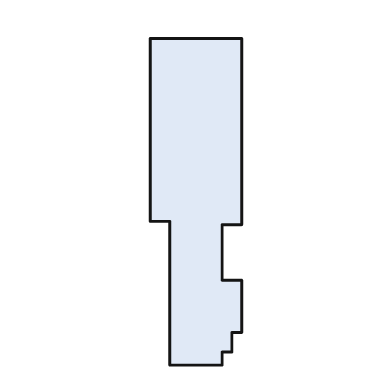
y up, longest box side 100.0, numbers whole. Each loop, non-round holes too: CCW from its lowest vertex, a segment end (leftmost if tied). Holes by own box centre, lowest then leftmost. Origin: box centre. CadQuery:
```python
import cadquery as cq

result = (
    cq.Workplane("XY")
    .moveTo(-8.0, -50.0)
    .lineTo(8.0, -50.0)
    .lineTo(8.0, -46.0)
    .lineTo(11.0, -46.0)
    .lineTo(11.0, -40.0)
    .lineTo(14.0, -40.0)
    .lineTo(14.0, -24.0)
    .lineTo(8.0, -24.0)
    .lineTo(8.0, -7.0)
    .lineTo(14.0, -7.0)
    .lineTo(14.0, 50.0)
    .lineTo(-14.0, 50.0)
    .lineTo(-14.0, -6.0)
    .lineTo(-8.0, -6.0)
    .close()
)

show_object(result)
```